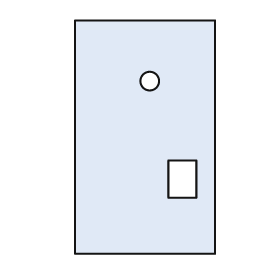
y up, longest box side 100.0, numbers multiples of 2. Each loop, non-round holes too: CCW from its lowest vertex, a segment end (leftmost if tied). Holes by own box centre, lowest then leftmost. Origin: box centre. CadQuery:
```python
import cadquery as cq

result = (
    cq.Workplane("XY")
    .moveTo(-30.0, -50.0)
    .lineTo(30.0, -50.0)
    .lineTo(30.0, 50.0)
    .lineTo(-30.0, 50.0)
    .close()
    .moveTo(10.0, -26.0)
    .lineTo(22.0, -26.0)
    .lineTo(22.0, -10.0)
    .lineTo(10.0, -10.0)
    .close()
    .moveTo(2.0, 24.0)
    .circle(4.0)
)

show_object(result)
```